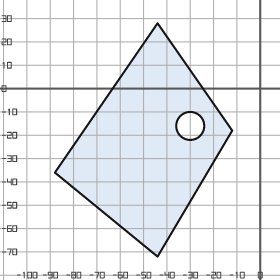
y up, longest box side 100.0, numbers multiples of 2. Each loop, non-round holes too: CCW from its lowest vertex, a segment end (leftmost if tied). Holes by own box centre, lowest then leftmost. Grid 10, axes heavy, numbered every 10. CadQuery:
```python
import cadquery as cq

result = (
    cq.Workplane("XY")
    .moveTo(-44.0, -72.0)
    .lineTo(-12.0, -18.0)
    .lineTo(-44.0, 28.0)
    .lineTo(-88.0, -36.0)
    .close()
    .moveTo(-30.0, -16.0)
    .circle(6.0)
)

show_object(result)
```